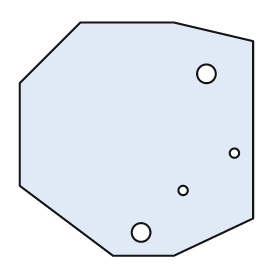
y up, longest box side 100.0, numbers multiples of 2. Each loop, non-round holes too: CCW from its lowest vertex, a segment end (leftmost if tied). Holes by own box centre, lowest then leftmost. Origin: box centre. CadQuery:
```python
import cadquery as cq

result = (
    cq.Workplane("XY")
    .moveTo(-10.0, -50.0)
    .lineTo(16.0, -50.0)
    .lineTo(50.0, -34.0)
    .lineTo(50.0, 42.0)
    .lineTo(16.0, 50.0)
    .lineTo(-24.0, 50.0)
    .lineTo(-50.0, 24.0)
    .lineTo(-50.0, -20.0)
    .close()
    .moveTo(2.0, -40.0)
    .circle(4.0)
    .moveTo(20.0, -22.0)
    .circle(2.0)
    .moveTo(42.0, -6.0)
    .circle(2.0)
    .moveTo(30.0, 28.0)
    .circle(4.0)
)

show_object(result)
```